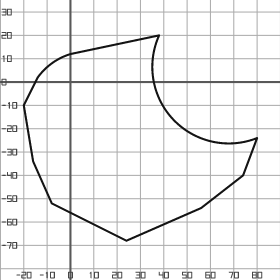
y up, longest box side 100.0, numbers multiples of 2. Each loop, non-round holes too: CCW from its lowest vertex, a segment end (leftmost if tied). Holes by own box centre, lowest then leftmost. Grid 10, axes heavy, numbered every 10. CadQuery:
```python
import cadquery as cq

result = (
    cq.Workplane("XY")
    .moveTo(24.0, -68.0)
    .lineTo(56.0, -54.0)
    .lineTo(74.0, -40.0)
    .lineTo(80.0, -24.0)
    .threePointArc((44.0, -16.0), (38.0, 20.0))
    .lineTo(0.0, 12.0)
    .threePointArc((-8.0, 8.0), (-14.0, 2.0))
    .lineTo(-20.0, -10.0)
    .lineTo(-16.0, -34.0)
    .lineTo(-8.0, -52.0)
    .close()
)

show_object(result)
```